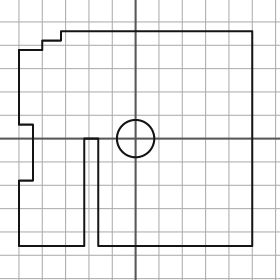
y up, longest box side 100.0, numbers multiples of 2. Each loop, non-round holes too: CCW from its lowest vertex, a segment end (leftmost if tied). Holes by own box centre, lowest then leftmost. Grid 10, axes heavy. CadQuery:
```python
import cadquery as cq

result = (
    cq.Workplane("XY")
    .moveTo(-50.0, -46.0)
    .lineTo(-22.0, -46.0)
    .lineTo(-22.0, 0.0)
    .lineTo(-16.0, 0.0)
    .lineTo(-16.0, -46.0)
    .lineTo(50.0, -46.0)
    .lineTo(50.0, 46.0)
    .lineTo(-32.0, 46.0)
    .lineTo(-32.0, 42.0)
    .lineTo(-40.0, 42.0)
    .lineTo(-40.0, 38.0)
    .lineTo(-50.0, 38.0)
    .lineTo(-50.0, 6.0)
    .lineTo(-44.0, 6.0)
    .lineTo(-44.0, -18.0)
    .lineTo(-50.0, -18.0)
    .close()
    .moveTo(0.0, 0.0)
    .circle(8.0)
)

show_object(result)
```